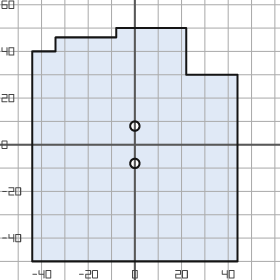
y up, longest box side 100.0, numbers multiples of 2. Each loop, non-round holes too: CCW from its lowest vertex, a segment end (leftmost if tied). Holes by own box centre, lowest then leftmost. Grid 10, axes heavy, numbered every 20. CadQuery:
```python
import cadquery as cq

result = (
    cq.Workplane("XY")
    .moveTo(-44.0, -50.0)
    .lineTo(44.0, -50.0)
    .lineTo(44.0, 30.0)
    .lineTo(22.0, 30.0)
    .lineTo(22.0, 50.0)
    .lineTo(-8.0, 50.0)
    .lineTo(-8.0, 46.0)
    .lineTo(-34.0, 46.0)
    .lineTo(-34.0, 40.0)
    .lineTo(-44.0, 40.0)
    .close()
    .moveTo(0.0, -8.0)
    .circle(2.0)
    .moveTo(0.0, 8.0)
    .circle(2.0)
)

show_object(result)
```